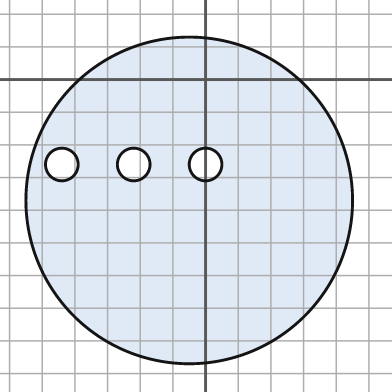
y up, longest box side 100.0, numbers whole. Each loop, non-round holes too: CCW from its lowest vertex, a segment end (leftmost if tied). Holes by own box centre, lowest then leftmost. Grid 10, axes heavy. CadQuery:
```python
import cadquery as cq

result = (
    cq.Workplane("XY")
    .moveTo(-5.0, -37.0)
    .circle(50.0)
    .moveTo(-44.0, -26.0)
    .circle(5.0)
    .moveTo(-22.0, -26.0)
    .circle(5.0)
    .moveTo(0.0, -26.0)
    .circle(5.0)
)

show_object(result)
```